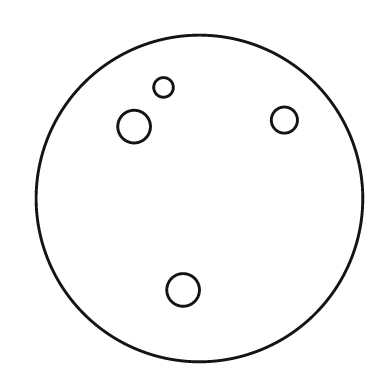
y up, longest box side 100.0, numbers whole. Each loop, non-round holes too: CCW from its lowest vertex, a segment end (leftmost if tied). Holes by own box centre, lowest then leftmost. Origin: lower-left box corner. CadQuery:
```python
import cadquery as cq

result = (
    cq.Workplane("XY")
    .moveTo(50.0, 50.0)
    .circle(50.0)
    .moveTo(45.0, 22.0)
    .circle(5.0)
    .moveTo(30.0, 72.0)
    .circle(5.0)
    .moveTo(76.0, 74.0)
    .circle(4.0)
    .moveTo(39.0, 84.0)
    .circle(3.0)
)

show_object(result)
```